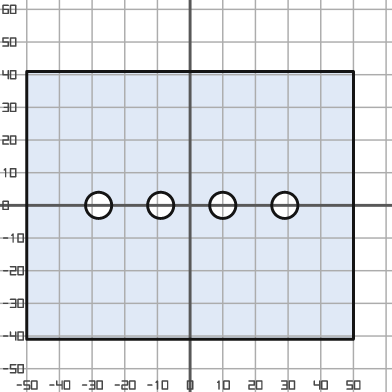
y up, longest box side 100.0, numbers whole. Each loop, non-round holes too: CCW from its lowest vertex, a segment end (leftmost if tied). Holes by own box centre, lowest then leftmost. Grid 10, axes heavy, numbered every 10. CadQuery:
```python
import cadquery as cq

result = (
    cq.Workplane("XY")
    .moveTo(-50.0, -41.0)
    .lineTo(50.0, -41.0)
    .lineTo(50.0, 41.0)
    .lineTo(-50.0, 41.0)
    .close()
    .moveTo(-28.0, 0.0)
    .circle(4.0)
    .moveTo(-9.0, 0.0)
    .circle(4.0)
    .moveTo(10.0, 0.0)
    .circle(4.0)
    .moveTo(29.0, 0.0)
    .circle(4.0)
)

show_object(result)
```